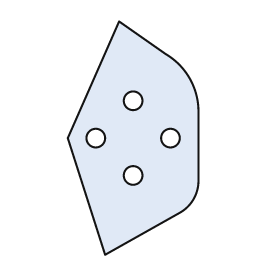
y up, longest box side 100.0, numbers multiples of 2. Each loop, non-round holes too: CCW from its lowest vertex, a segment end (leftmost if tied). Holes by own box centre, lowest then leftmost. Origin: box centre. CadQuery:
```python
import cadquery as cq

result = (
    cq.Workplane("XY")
    .moveTo(-12.0, -50.0)
    .lineTo(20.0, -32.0)
    .threePointArc((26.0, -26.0), (28.0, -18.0))
    .lineTo(28.0, 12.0)
    .threePointArc((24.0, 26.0), (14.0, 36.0))
    .lineTo(-6.0, 50.0)
    .lineTo(-28.0, 0.0)
    .close()
    .moveTo(0.0, -16.0)
    .circle(4.0)
    .moveTo(-16.0, 0.0)
    .circle(4.0)
    .moveTo(16.0, 0.0)
    .circle(4.0)
    .moveTo(0.0, 16.0)
    .circle(4.0)
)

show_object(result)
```